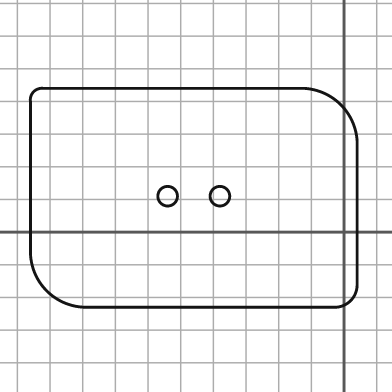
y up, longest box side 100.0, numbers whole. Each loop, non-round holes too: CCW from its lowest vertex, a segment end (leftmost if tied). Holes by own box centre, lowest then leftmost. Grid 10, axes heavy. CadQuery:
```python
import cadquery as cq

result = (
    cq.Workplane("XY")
    .moveTo(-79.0, -23.0)
    .lineTo(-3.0, -23.0)
    .threePointArc((2.0, -21.0), (4.0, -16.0))
    .lineTo(4.0, 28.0)
    .threePointArc((-1.0, 39.0), (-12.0, 44.0))
    .lineTo(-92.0, 44.0)
    .threePointArc((-95.0, 43.0), (-96.0, 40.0))
    .lineTo(-96.0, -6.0)
    .threePointArc((-91.0, -18.0), (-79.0, -23.0))
    .close()
    .moveTo(-54.0, 11.0)
    .circle(3.0)
    .moveTo(-38.0, 11.0)
    .circle(3.0)
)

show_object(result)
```